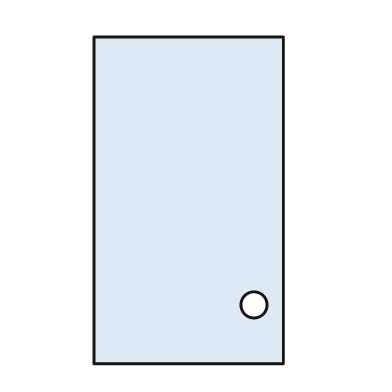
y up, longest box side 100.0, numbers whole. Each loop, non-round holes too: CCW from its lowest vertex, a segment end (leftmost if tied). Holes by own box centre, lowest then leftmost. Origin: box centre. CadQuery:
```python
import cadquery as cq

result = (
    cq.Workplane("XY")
    .moveTo(-29.0, -50.0)
    .lineTo(29.0, -50.0)
    .lineTo(29.0, 50.0)
    .lineTo(-29.0, 50.0)
    .close()
    .moveTo(20.0, -32.0)
    .circle(4.0)
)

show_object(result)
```